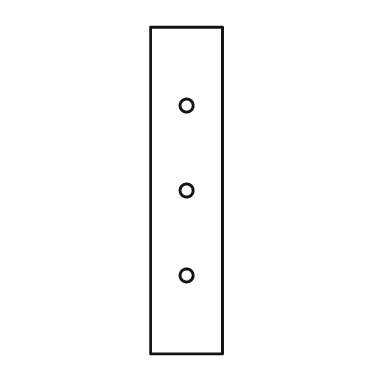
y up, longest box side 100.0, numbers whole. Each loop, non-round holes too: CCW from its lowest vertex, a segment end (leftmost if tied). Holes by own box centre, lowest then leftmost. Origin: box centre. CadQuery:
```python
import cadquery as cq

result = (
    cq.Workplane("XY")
    .moveTo(-11.0, -50.0)
    .lineTo(11.0, -50.0)
    .lineTo(11.0, 50.0)
    .lineTo(-11.0, 50.0)
    .close()
    .moveTo(0.0, -26.0)
    .circle(2.0)
    .moveTo(0.0, 0.0)
    .circle(2.0)
    .moveTo(0.0, 26.0)
    .circle(2.0)
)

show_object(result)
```